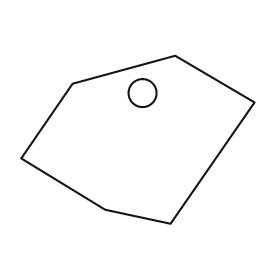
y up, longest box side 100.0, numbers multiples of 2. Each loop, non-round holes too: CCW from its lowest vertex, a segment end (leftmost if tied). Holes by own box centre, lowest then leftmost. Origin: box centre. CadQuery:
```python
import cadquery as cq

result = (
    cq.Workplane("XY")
    .moveTo(14.0, -36.0)
    .lineTo(50.0, 16.0)
    .lineTo(16.0, 36.0)
    .lineTo(-28.0, 24.0)
    .lineTo(-50.0, -8.0)
    .lineTo(-14.0, -30.0)
    .close()
    .moveTo(2.0, 20.0)
    .circle(6.0)
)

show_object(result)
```